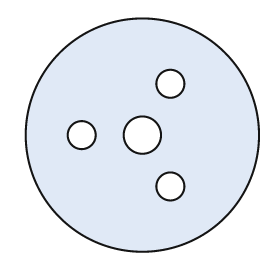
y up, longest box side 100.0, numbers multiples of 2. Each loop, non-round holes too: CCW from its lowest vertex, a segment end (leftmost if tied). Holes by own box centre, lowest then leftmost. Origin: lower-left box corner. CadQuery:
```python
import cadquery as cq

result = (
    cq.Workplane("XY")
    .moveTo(50.0, 50.0)
    .circle(50.0)
    .moveTo(62.0, 28.0)
    .circle(6.0)
    .moveTo(24.0, 50.0)
    .circle(6.0)
    .moveTo(50.0, 50.0)
    .circle(8.0)
    .moveTo(62.0, 72.0)
    .circle(6.0)
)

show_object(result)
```